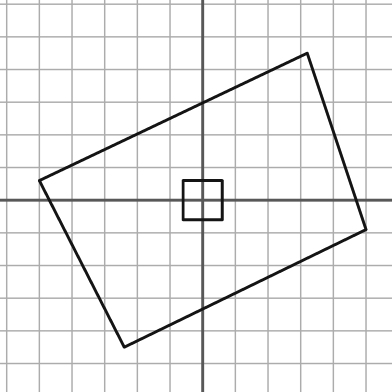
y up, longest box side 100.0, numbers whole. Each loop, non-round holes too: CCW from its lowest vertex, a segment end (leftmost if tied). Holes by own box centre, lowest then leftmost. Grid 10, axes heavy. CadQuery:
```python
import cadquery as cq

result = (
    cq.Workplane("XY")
    .moveTo(-24.0, -45.0)
    .lineTo(50.0, -9.0)
    .lineTo(32.0, 45.0)
    .lineTo(-50.0, 6.0)
    .close()
    .moveTo(-6.0, -6.0)
    .lineTo(6.0, -6.0)
    .lineTo(6.0, 6.0)
    .lineTo(-6.0, 6.0)
    .close()
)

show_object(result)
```